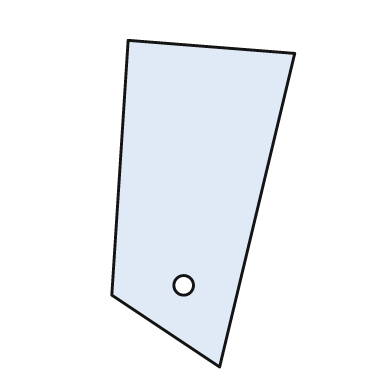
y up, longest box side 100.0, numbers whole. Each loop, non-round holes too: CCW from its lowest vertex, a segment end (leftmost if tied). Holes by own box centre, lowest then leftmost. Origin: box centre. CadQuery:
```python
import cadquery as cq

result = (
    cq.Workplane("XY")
    .moveTo(5.0, -50.0)
    .lineTo(28.0, 46.0)
    .lineTo(-23.0, 50.0)
    .lineTo(-28.0, -28.0)
    .close()
    .moveTo(-6.0, -25.0)
    .circle(3.0)
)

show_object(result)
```